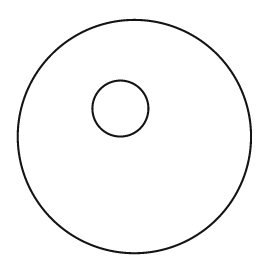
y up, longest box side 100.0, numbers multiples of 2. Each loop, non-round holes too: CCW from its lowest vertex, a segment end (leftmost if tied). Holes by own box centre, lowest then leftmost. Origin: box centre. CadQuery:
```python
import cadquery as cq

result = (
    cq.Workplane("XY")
    .moveTo(0.0, 0.0)
    .circle(50.0)
    .moveTo(-6.0, 12.0)
    .circle(12.0)
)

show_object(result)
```